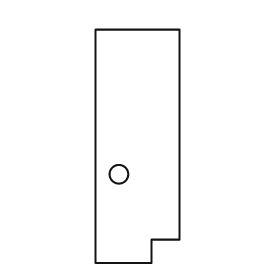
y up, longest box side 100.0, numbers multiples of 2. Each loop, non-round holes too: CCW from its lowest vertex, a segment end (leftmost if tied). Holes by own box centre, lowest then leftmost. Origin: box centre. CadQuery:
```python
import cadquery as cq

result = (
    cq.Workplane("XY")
    .moveTo(-18.0, -50.0)
    .lineTo(6.0, -50.0)
    .lineTo(6.0, -40.0)
    .lineTo(18.0, -40.0)
    .lineTo(18.0, 50.0)
    .lineTo(-18.0, 50.0)
    .close()
    .moveTo(-8.0, -12.0)
    .circle(4.0)
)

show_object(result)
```